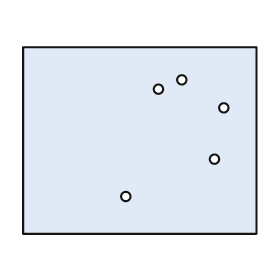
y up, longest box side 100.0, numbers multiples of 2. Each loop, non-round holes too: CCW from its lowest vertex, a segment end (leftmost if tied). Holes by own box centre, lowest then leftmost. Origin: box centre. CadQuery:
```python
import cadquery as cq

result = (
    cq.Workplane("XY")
    .moveTo(-50.0, -40.0)
    .lineTo(50.0, -40.0)
    .lineTo(50.0, 40.0)
    .lineTo(-50.0, 40.0)
    .close()
    .moveTo(-6.0, -24.0)
    .circle(2.0)
    .moveTo(32.0, -8.0)
    .circle(2.0)
    .moveTo(36.0, 14.0)
    .circle(2.0)
    .moveTo(8.0, 22.0)
    .circle(2.0)
    .moveTo(18.0, 26.0)
    .circle(2.0)
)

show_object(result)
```